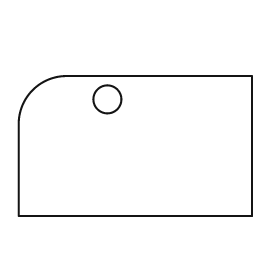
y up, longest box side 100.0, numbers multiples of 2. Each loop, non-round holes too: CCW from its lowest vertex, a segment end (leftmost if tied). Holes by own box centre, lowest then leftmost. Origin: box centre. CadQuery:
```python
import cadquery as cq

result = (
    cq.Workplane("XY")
    .moveTo(-50.0, -30.0)
    .lineTo(50.0, -30.0)
    .lineTo(50.0, 30.0)
    .lineTo(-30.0, 30.0)
    .threePointArc((-44.0, 24.0), (-50.0, 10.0))
    .close()
    .moveTo(-12.0, 20.0)
    .circle(6.0)
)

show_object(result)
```